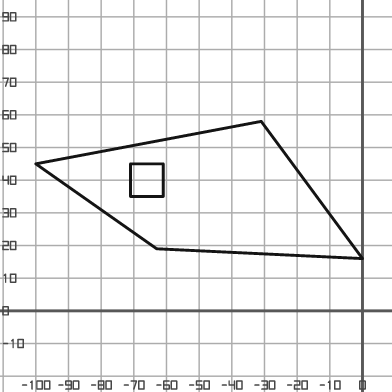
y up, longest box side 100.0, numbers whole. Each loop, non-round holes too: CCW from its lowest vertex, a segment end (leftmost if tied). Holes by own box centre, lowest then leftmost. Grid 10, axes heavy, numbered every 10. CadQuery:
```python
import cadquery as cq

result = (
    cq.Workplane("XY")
    .moveTo(0.0, 16.0)
    .lineTo(-31.0, 58.0)
    .lineTo(-100.0, 45.0)
    .lineTo(-63.0, 19.0)
    .close()
    .moveTo(-71.0, 35.0)
    .lineTo(-61.0, 35.0)
    .lineTo(-61.0, 45.0)
    .lineTo(-71.0, 45.0)
    .close()
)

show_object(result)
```